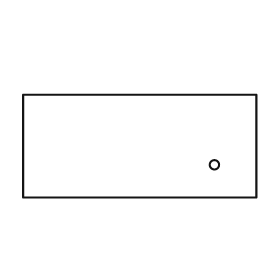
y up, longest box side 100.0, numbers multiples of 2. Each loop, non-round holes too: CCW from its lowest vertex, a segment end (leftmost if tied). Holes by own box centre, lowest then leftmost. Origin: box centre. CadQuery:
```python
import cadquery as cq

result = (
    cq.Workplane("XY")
    .moveTo(-50.0, -22.0)
    .lineTo(50.0, -22.0)
    .lineTo(50.0, 22.0)
    .lineTo(-50.0, 22.0)
    .close()
    .moveTo(32.0, -8.0)
    .circle(2.0)
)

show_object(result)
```